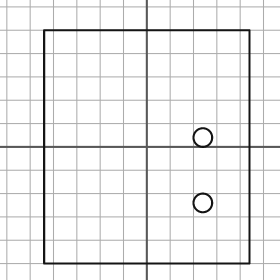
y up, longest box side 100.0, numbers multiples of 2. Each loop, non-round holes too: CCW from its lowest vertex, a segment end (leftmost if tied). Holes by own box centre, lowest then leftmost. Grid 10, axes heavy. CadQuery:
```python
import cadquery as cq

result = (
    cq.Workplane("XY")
    .moveTo(-44.0, -50.0)
    .lineTo(44.0, -50.0)
    .lineTo(44.0, 50.0)
    .lineTo(-44.0, 50.0)
    .close()
    .moveTo(24.0, -24.0)
    .circle(4.0)
    .moveTo(24.0, 4.0)
    .circle(4.0)
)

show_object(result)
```